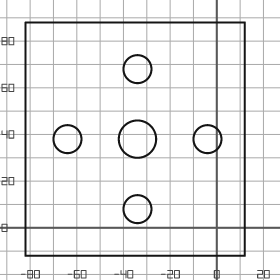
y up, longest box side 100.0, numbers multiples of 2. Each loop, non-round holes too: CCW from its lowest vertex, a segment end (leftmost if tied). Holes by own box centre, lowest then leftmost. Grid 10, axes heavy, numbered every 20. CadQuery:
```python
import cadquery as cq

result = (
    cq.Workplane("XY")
    .moveTo(-82.0, -12.0)
    .lineTo(12.0, -12.0)
    .lineTo(12.0, 88.0)
    .lineTo(-82.0, 88.0)
    .close()
    .moveTo(-34.0, 8.0)
    .circle(6.0)
    .moveTo(-64.0, 38.0)
    .circle(6.0)
    .moveTo(-34.0, 38.0)
    .circle(8.0)
    .moveTo(-4.0, 38.0)
    .circle(6.0)
    .moveTo(-34.0, 68.0)
    .circle(6.0)
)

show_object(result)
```